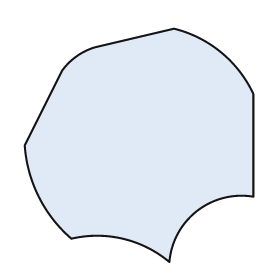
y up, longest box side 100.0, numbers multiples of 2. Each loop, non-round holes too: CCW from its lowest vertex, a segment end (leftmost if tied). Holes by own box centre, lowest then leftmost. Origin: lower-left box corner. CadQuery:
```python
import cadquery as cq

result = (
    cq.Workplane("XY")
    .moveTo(62.0, 0.0)
    .threePointArc((74.0, 22.0), (98.0, 28.0))
    .lineTo(98.0, 72.0)
    .threePointArc((84.0, 90.0), (64.0, 100.0))
    .lineTo(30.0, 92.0)
    .threePointArc((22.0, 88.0), (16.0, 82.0))
    .lineTo(0.0, 50.0)
    .threePointArc((6.0, 28.0), (20.0, 10.0))
    .threePointArc((42.0, 10.0), (62.0, 0.0))
    .close()
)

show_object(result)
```